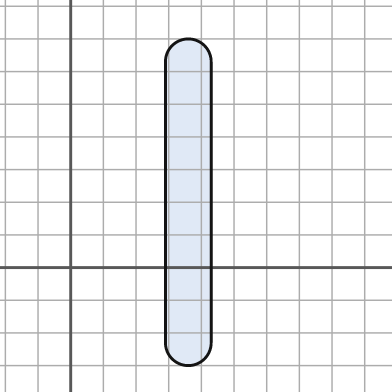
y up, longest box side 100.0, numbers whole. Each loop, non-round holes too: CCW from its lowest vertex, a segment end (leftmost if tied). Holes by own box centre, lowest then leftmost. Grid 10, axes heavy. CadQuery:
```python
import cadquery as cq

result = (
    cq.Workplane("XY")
    .moveTo(29.0, -23.0)
    .threePointArc((36.0, -30.0), (43.0, -23.0))
    .lineTo(43.0, 63.0)
    .threePointArc((36.0, 70.0), (29.0, 63.0))
    .close()
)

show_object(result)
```